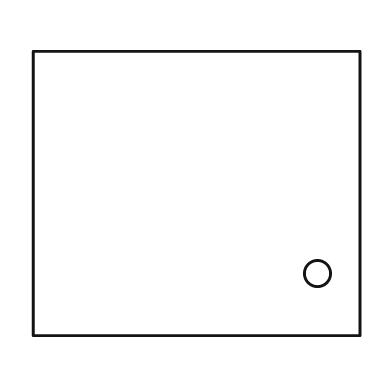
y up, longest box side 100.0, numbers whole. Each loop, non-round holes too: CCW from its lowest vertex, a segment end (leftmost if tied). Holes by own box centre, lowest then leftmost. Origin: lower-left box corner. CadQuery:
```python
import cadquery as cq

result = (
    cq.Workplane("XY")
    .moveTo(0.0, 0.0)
    .lineTo(100.0, 0.0)
    .lineTo(100.0, 87.0)
    .lineTo(0.0, 87.0)
    .close()
    .moveTo(87.0, 19.0)
    .circle(4.0)
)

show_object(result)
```